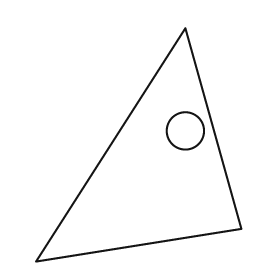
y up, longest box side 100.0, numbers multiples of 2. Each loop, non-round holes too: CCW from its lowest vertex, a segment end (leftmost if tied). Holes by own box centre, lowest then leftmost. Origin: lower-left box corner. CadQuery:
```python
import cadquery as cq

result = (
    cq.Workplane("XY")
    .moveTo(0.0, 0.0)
    .lineTo(88.0, 14.0)
    .lineTo(64.0, 100.0)
    .close()
    .moveTo(64.0, 56.0)
    .circle(8.0)
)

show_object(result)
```